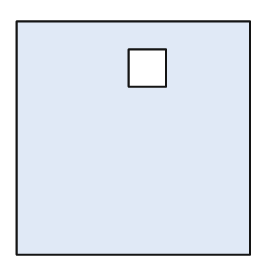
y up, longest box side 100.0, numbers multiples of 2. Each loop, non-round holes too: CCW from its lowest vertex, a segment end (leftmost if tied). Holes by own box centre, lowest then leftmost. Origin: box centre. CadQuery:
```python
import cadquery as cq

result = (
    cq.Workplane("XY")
    .moveTo(-50.0, -50.0)
    .lineTo(50.0, -50.0)
    .lineTo(50.0, 50.0)
    .lineTo(-50.0, 50.0)
    .close()
    .moveTo(-2.0, 22.0)
    .lineTo(14.0, 22.0)
    .lineTo(14.0, 38.0)
    .lineTo(-2.0, 38.0)
    .close()
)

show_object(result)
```